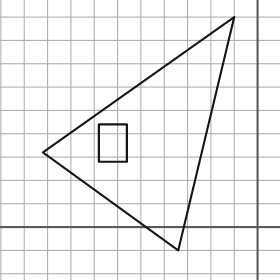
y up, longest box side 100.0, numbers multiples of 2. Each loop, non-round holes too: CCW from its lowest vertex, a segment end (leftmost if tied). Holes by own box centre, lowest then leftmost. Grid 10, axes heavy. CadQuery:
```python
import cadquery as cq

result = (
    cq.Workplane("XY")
    .moveTo(-34.0, -10.0)
    .lineTo(-10.0, 90.0)
    .lineTo(-92.0, 32.0)
    .close()
    .moveTo(-68.0, 28.0)
    .lineTo(-56.0, 28.0)
    .lineTo(-56.0, 44.0)
    .lineTo(-68.0, 44.0)
    .close()
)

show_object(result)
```